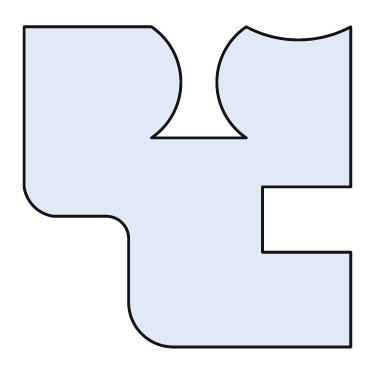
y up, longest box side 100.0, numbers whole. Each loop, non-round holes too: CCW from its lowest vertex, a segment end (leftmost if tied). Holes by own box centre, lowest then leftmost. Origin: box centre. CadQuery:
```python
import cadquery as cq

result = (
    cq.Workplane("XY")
    .moveTo(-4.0, -49.0)
    .lineTo(50.0, -49.0)
    .lineTo(50.0, -20.0)
    .lineTo(23.0, -20.0)
    .lineTo(23.0, 0.0)
    .lineTo(50.0, 0.0)
    .lineTo(50.0, 49.0)
    .threePointArc((34.0, 45.0), (18.0, 49.0))
    .threePointArc((9.0, 32.0), (18.0, 15.0))
    .lineTo(-11.0, 15.0)
    .threePointArc((-2.0, 32.0), (-11.0, 49.0))
    .lineTo(-50.0, 49.0)
    .lineTo(-50.0, 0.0)
    .threePointArc((-47.0, -6.0), (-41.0, -9.0))
    .lineTo(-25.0, -9.0)
    .threePointArc((-20.0, -11.0), (-18.0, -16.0))
    .lineTo(-18.0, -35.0)
    .threePointArc((-14.0, -45.0), (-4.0, -49.0))
    .close()
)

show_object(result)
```